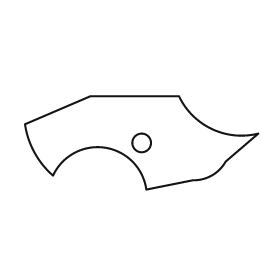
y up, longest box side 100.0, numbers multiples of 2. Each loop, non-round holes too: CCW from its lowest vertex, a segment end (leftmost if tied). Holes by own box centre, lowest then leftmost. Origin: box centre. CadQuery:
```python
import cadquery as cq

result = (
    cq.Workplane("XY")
    .moveTo(2.0, -20.0)
    .lineTo(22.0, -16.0)
    .threePointArc((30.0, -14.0), (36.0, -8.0))
    .lineTo(50.0, 4.0)
    .threePointArc((30.0, 6.0), (16.0, 20.0))
    .lineTo(-22.0, 20.0)
    .lineTo(-50.0, 8.0)
    .threePointArc((-46.0, -4.0), (-38.0, -14.0))
    .threePointArc((-16.0, -2.0), (2.0, -20.0))
    .close()
    .moveTo(0.0, 0.0)
    .circle(4.0)
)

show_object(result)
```